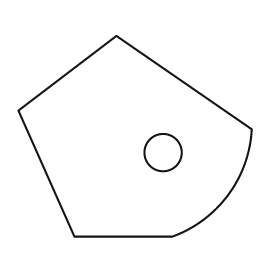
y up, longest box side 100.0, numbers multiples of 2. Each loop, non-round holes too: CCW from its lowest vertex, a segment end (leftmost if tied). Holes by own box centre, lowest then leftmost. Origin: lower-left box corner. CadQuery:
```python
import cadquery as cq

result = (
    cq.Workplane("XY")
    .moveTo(24.0, 0.0)
    .lineTo(66.0, 0.0)
    .threePointArc((90.0, 18.0), (100.0, 46.0))
    .lineTo(42.0, 86.0)
    .lineTo(0.0, 54.0)
    .close()
    .moveTo(62.0, 36.0)
    .circle(8.0)
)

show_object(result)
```